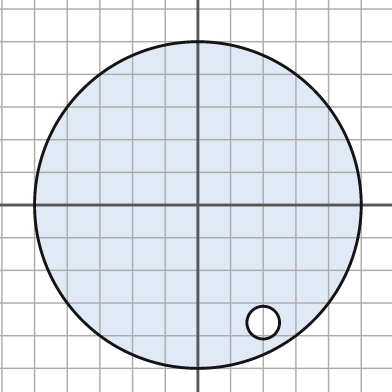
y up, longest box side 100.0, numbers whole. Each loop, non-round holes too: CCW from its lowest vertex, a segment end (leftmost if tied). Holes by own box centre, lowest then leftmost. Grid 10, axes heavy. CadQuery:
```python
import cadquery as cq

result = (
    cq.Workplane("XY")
    .moveTo(0.0, 0.0)
    .circle(50.0)
    .moveTo(20.0, -36.0)
    .circle(5.0)
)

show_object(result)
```